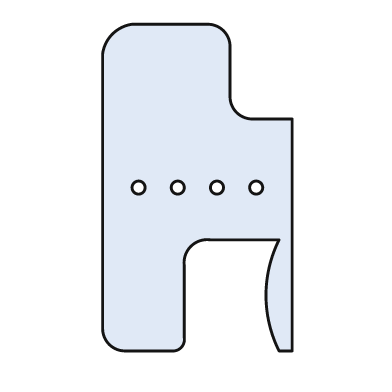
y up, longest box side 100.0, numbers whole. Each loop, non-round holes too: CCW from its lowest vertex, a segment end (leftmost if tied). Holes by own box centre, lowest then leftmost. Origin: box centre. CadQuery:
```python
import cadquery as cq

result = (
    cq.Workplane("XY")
    .moveTo(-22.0, -50.0)
    .lineTo(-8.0, -50.0)
    .threePointArc((-5.0, -49.0), (-4.0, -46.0))
    .lineTo(-4.0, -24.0)
    .threePointArc((-2.0, -18.0), (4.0, -16.0))
    .lineTo(25.0, -16.0)
    .threePointArc((21.0, -33.0), (25.0, -50.0))
    .lineTo(29.0, -50.0)
    .lineTo(29.0, 21.0)
    .lineTo(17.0, 21.0)
    .threePointArc((12.0, 23.0), (10.0, 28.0))
    .lineTo(10.0, 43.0)
    .threePointArc((8.0, 48.0), (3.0, 50.0))
    .lineTo(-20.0, 50.0)
    .threePointArc((-26.0, 47.0), (-29.0, 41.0))
    .lineTo(-29.0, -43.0)
    .threePointArc((-27.0, -48.0), (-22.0, -50.0))
    .close()
    .moveTo(-18.0, 0.0)
    .circle(2.0)
    .moveTo(-6.0, 0.0)
    .circle(2.0)
    .moveTo(6.0, 0.0)
    .circle(2.0)
    .moveTo(18.0, 0.0)
    .circle(2.0)
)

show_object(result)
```